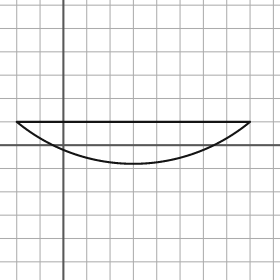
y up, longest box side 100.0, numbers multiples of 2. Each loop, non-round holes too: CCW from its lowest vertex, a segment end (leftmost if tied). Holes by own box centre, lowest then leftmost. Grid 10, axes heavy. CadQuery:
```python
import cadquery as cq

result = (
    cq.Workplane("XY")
    .moveTo(-20.0, 10.0)
    .threePointArc((30.0, -8.0), (80.0, 10.0))
    .close()
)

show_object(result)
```